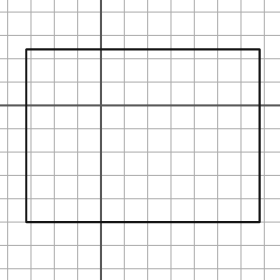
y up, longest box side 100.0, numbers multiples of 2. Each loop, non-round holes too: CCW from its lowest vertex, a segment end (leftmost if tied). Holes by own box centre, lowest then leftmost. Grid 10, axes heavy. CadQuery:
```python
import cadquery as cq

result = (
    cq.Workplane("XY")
    .moveTo(-32.0, -50.0)
    .lineTo(68.0, -50.0)
    .lineTo(68.0, 24.0)
    .lineTo(-32.0, 24.0)
    .close()
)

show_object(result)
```